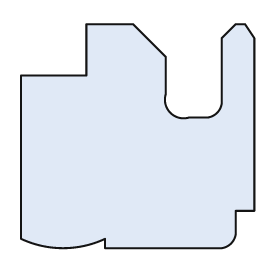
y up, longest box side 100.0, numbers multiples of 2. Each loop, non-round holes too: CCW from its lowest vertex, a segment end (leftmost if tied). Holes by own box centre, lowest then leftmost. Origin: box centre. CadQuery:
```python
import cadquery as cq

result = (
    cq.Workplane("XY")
    .moveTo(-14.0, -48.0)
    .lineTo(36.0, -48.0)
    .threePointArc((40.0, -46.0), (42.0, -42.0))
    .lineTo(42.0, -32.0)
    .lineTo(50.0, -32.0)
    .lineTo(50.0, 42.0)
    .lineTo(46.0, 48.0)
    .lineTo(42.0, 48.0)
    .lineTo(36.0, 42.0)
    .lineTo(36.0, 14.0)
    .threePointArc((34.0, 10.0), (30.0, 8.0))
    .lineTo(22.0, 8.0)
    .threePointArc((14.0, 10.0), (12.0, 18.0))
    .lineTo(12.0, 34.0)
    .lineTo(-2.0, 48.0)
    .lineTo(-22.0, 48.0)
    .lineTo(-22.0, 26.0)
    .lineTo(-50.0, 26.0)
    .lineTo(-50.0, -44.0)
    .threePointArc((-32.0, -48.0), (-14.0, -44.0))
    .close()
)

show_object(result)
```